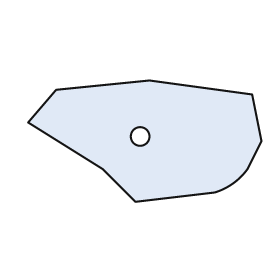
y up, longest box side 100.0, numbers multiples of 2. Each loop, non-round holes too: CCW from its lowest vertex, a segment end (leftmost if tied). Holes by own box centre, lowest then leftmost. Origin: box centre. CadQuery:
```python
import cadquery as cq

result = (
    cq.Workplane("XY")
    .moveTo(-4.0, -26.0)
    .lineTo(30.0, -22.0)
    .threePointArc((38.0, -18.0), (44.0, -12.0))
    .lineTo(50.0, 0.0)
    .lineTo(46.0, 20.0)
    .lineTo(2.0, 26.0)
    .lineTo(-38.0, 22.0)
    .lineTo(-50.0, 8.0)
    .lineTo(-18.0, -12.0)
    .close()
    .moveTo(-2.0, 2.0)
    .circle(4.0)
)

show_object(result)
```